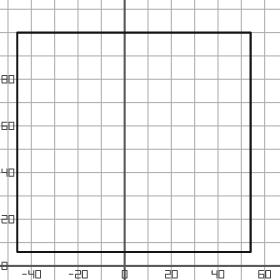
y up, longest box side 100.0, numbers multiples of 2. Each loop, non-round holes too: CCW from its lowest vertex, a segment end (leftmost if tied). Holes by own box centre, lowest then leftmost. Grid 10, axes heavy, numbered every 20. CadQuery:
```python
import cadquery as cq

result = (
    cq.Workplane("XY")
    .moveTo(-46.0, 6.0)
    .lineTo(54.0, 6.0)
    .lineTo(54.0, 100.0)
    .lineTo(-46.0, 100.0)
    .close()
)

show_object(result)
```